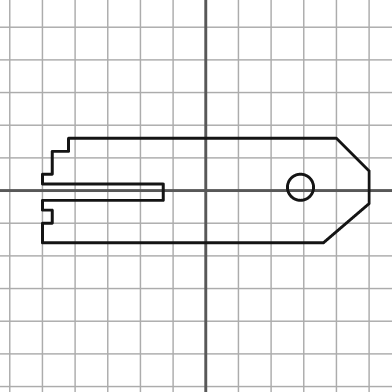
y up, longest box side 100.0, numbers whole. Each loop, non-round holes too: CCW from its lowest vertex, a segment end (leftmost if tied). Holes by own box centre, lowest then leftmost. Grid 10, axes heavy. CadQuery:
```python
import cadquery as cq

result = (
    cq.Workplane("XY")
    .moveTo(-50.0, -16.0)
    .lineTo(36.0, -16.0)
    .lineTo(50.0, -4.0)
    .lineTo(50.0, 6.0)
    .lineTo(40.0, 16.0)
    .lineTo(-42.0, 16.0)
    .lineTo(-42.0, 12.0)
    .lineTo(-47.0, 12.0)
    .lineTo(-47.0, 5.0)
    .lineTo(-50.0, 5.0)
    .lineTo(-50.0, 2.0)
    .lineTo(-13.0, 2.0)
    .lineTo(-13.0, -3.0)
    .lineTo(-50.0, -3.0)
    .lineTo(-50.0, -6.0)
    .lineTo(-47.0, -6.0)
    .lineTo(-47.0, -10.0)
    .lineTo(-50.0, -10.0)
    .close()
    .moveTo(29.0, 1.0)
    .circle(4.0)
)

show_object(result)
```